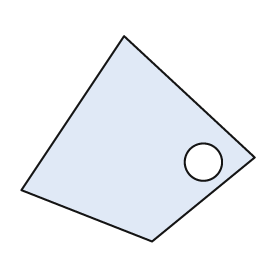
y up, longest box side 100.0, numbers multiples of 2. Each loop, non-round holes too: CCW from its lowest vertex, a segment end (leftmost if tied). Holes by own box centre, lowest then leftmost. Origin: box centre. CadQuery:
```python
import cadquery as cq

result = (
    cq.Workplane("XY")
    .moveTo(6.0, -44.0)
    .lineTo(50.0, -8.0)
    .lineTo(-6.0, 44.0)
    .lineTo(-50.0, -22.0)
    .close()
    .moveTo(28.0, -10.0)
    .circle(8.0)
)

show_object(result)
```